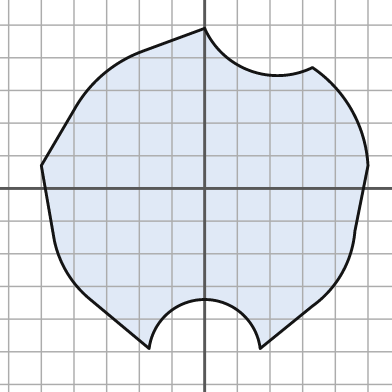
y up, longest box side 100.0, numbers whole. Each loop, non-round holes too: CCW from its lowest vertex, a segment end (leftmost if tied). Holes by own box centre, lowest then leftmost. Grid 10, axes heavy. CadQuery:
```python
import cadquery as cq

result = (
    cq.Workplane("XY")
    .moveTo(-17.0, -49.0)
    .threePointArc((0.0, -34.0), (17.0, -49.0))
    .lineTo(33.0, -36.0)
    .threePointArc((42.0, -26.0), (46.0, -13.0))
    .lineTo(50.0, 7.0)
    .threePointArc((45.0, 24.0), (33.0, 37.0))
    .threePointArc((14.0, 36.0), (0.0, 49.0))
    .lineTo(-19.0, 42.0)
    .threePointArc((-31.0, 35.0), (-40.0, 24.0))
    .lineTo(-50.0, 7.0)
    .lineTo(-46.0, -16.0)
    .threePointArc((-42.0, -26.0), (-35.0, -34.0))
    .close()
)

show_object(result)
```